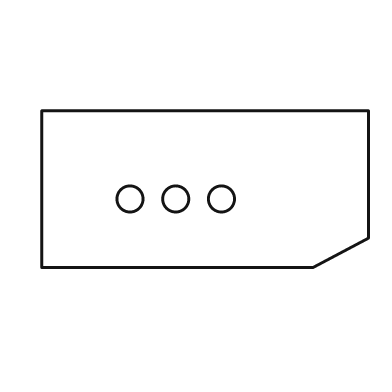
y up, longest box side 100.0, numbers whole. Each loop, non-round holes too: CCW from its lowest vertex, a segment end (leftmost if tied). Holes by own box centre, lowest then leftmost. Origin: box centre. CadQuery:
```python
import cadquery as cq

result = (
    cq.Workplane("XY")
    .moveTo(-50.0, -24.0)
    .lineTo(33.0, -24.0)
    .lineTo(50.0, -15.0)
    .lineTo(50.0, 24.0)
    .lineTo(-50.0, 24.0)
    .close()
    .moveTo(-23.0, -3.0)
    .circle(4.0)
    .moveTo(-9.0, -3.0)
    .circle(4.0)
    .moveTo(5.0, -3.0)
    .circle(4.0)
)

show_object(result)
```